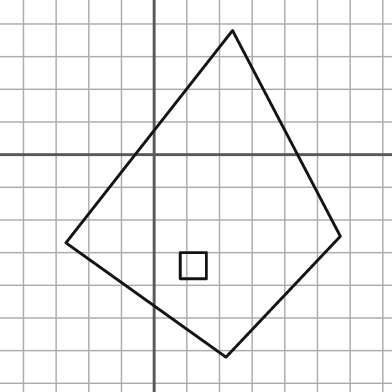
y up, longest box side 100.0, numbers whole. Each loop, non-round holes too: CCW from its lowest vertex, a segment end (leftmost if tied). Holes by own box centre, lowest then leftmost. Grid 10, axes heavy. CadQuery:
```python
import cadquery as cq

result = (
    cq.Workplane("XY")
    .moveTo(22.0, -62.0)
    .lineTo(57.0, -25.0)
    .lineTo(24.0, 38.0)
    .lineTo(-27.0, -27.0)
    .close()
    .moveTo(8.0, -38.0)
    .lineTo(16.0, -38.0)
    .lineTo(16.0, -30.0)
    .lineTo(8.0, -30.0)
    .close()
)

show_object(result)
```